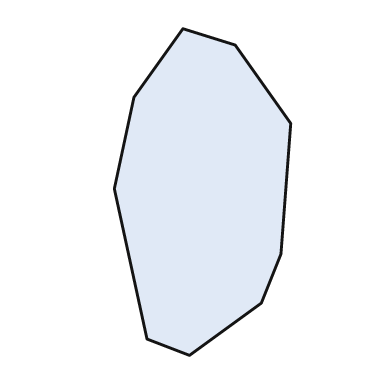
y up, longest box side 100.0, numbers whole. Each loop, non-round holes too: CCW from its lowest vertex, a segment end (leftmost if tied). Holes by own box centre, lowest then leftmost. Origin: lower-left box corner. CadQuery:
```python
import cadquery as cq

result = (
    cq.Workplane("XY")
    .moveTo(23.0, 0.0)
    .lineTo(45.0, 16.0)
    .lineTo(51.0, 31.0)
    .lineTo(54.0, 71.0)
    .lineTo(37.0, 95.0)
    .lineTo(21.0, 100.0)
    .lineTo(6.0, 79.0)
    .lineTo(0.0, 51.0)
    .lineTo(10.0, 5.0)
    .close()
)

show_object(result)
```